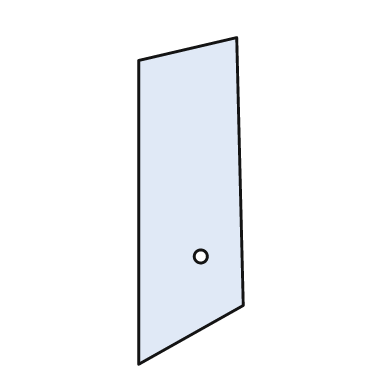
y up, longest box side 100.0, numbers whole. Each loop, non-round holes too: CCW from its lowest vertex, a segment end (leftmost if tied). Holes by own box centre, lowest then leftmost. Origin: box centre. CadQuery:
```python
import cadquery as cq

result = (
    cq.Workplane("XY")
    .moveTo(-16.0, -50.0)
    .lineTo(16.0, -32.0)
    .lineTo(14.0, 50.0)
    .lineTo(-16.0, 43.0)
    .close()
    .moveTo(3.0, -17.0)
    .circle(2.0)
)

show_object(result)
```